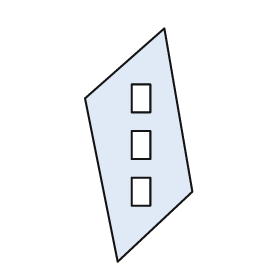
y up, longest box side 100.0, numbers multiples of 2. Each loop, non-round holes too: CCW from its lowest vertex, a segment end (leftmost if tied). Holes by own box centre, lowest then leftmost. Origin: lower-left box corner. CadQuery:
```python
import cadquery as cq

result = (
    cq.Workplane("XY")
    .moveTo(14.0, 0.0)
    .lineTo(46.0, 30.0)
    .lineTo(34.0, 100.0)
    .lineTo(0.0, 70.0)
    .close()
    .moveTo(20.0, 24.0)
    .lineTo(28.0, 24.0)
    .lineTo(28.0, 36.0)
    .lineTo(20.0, 36.0)
    .close()
    .moveTo(20.0, 44.0)
    .lineTo(28.0, 44.0)
    .lineTo(28.0, 56.0)
    .lineTo(20.0, 56.0)
    .close()
    .moveTo(20.0, 64.0)
    .lineTo(28.0, 64.0)
    .lineTo(28.0, 76.0)
    .lineTo(20.0, 76.0)
    .close()
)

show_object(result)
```